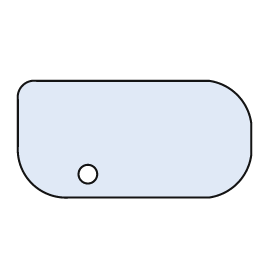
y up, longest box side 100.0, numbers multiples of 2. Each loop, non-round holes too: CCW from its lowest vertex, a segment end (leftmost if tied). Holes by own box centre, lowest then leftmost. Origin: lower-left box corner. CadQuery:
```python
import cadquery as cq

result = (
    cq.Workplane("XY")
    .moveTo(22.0, 0.0)
    .lineTo(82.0, 0.0)
    .threePointArc((94.0, 6.0), (100.0, 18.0))
    .lineTo(100.0, 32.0)
    .threePointArc((94.0, 44.0), (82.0, 50.0))
    .lineTo(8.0, 50.0)
    .threePointArc((2.0, 48.0), (0.0, 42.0))
    .lineTo(0.0, 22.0)
    .threePointArc((6.0, 6.0), (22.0, 0.0))
    .close()
    .moveTo(30.0, 10.0)
    .circle(4.0)
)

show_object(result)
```